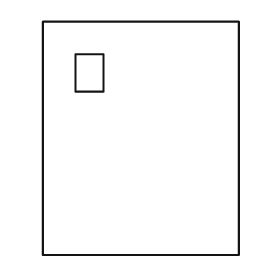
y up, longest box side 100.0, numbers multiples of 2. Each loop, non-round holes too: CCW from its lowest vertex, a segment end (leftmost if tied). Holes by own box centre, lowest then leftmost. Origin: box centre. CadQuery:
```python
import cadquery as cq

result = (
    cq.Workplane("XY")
    .moveTo(-42.0, -50.0)
    .lineTo(42.0, -50.0)
    .lineTo(42.0, 50.0)
    .lineTo(-42.0, 50.0)
    .close()
    .moveTo(-28.0, 20.0)
    .lineTo(-16.0, 20.0)
    .lineTo(-16.0, 36.0)
    .lineTo(-28.0, 36.0)
    .close()
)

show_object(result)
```